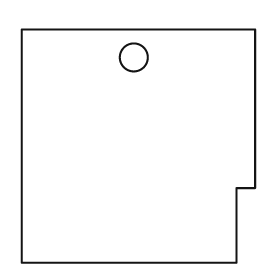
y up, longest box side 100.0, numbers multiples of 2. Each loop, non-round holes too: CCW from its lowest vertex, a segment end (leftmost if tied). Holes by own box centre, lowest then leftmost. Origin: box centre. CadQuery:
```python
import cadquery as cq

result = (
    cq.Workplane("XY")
    .moveTo(-50.0, -50.0)
    .lineTo(42.0, -50.0)
    .lineTo(42.0, -18.0)
    .lineTo(50.0, -18.0)
    .lineTo(50.0, 50.0)
    .lineTo(-50.0, 50.0)
    .close()
    .moveTo(-2.0, 38.0)
    .circle(6.0)
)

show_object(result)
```